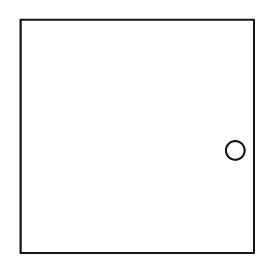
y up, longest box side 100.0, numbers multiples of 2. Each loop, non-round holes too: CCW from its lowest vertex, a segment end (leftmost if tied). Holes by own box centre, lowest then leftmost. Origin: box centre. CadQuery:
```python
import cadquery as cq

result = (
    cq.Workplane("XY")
    .moveTo(-50.0, -50.0)
    .lineTo(50.0, -50.0)
    .lineTo(50.0, 50.0)
    .lineTo(-50.0, 50.0)
    .close()
    .moveTo(42.0, -6.0)
    .circle(4.0)
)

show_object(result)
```